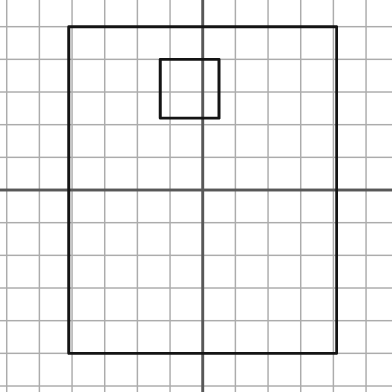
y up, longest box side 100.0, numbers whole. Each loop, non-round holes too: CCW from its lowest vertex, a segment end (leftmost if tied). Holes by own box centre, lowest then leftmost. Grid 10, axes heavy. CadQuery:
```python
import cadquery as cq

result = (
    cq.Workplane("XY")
    .moveTo(-41.0, -50.0)
    .lineTo(41.0, -50.0)
    .lineTo(41.0, 50.0)
    .lineTo(-41.0, 50.0)
    .close()
    .moveTo(-13.0, 22.0)
    .lineTo(5.0, 22.0)
    .lineTo(5.0, 40.0)
    .lineTo(-13.0, 40.0)
    .close()
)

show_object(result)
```